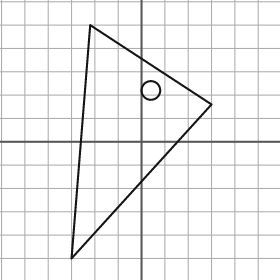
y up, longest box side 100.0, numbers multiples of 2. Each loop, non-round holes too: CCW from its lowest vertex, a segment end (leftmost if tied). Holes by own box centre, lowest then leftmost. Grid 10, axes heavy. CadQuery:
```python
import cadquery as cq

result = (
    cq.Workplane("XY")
    .moveTo(-30.0, -50.0)
    .lineTo(30.0, 16.0)
    .lineTo(-22.0, 50.0)
    .close()
    .moveTo(4.0, 22.0)
    .circle(4.0)
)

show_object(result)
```